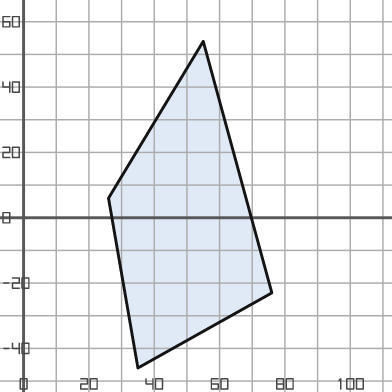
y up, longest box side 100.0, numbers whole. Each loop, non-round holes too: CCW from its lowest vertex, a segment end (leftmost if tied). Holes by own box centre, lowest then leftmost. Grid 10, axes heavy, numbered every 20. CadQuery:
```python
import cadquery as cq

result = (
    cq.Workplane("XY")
    .moveTo(35.0, -46.0)
    .lineTo(76.0, -23.0)
    .lineTo(55.0, 54.0)
    .lineTo(26.0, 6.0)
    .close()
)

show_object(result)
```